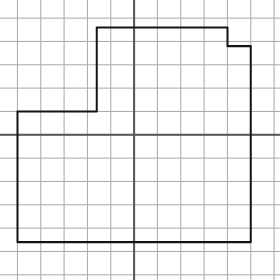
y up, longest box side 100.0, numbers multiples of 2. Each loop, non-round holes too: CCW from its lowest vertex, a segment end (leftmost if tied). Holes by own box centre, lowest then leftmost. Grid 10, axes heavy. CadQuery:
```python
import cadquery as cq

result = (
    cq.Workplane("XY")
    .moveTo(-50.0, -46.0)
    .lineTo(50.0, -46.0)
    .lineTo(50.0, 38.0)
    .lineTo(40.0, 38.0)
    .lineTo(40.0, 46.0)
    .lineTo(-16.0, 46.0)
    .lineTo(-16.0, 10.0)
    .lineTo(-50.0, 10.0)
    .close()
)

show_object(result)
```